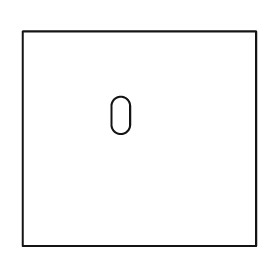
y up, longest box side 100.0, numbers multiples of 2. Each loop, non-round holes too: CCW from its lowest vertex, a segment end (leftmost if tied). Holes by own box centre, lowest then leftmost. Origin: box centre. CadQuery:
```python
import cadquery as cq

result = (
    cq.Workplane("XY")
    .moveTo(-50.0, -46.0)
    .lineTo(50.0, -46.0)
    .lineTo(50.0, 46.0)
    .lineTo(-50.0, 46.0)
    .close()
    .moveTo(-12.0, 6.0)
    .threePointArc((-8.0, 2.0), (-4.0, 6.0))
    .lineTo(-4.0, 14.0)
    .threePointArc((-8.0, 18.0), (-12.0, 14.0))
    .close()
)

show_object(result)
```